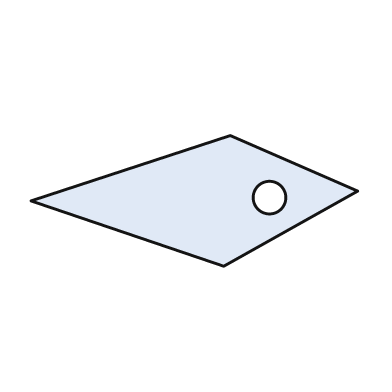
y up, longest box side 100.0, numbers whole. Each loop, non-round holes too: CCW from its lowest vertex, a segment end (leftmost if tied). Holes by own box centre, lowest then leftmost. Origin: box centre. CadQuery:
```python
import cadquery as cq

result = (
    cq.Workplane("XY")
    .moveTo(9.0, -20.0)
    .lineTo(50.0, 3.0)
    .lineTo(11.0, 20.0)
    .lineTo(-50.0, 0.0)
    .close()
    .moveTo(23.0, 1.0)
    .circle(5.0)
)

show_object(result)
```